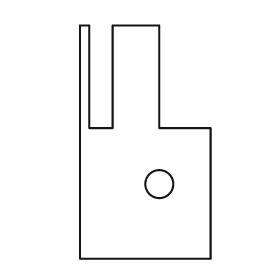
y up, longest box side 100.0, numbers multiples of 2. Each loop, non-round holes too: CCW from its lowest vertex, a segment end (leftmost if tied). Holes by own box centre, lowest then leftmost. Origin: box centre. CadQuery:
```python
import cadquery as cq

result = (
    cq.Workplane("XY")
    .moveTo(-28.0, -50.0)
    .lineTo(28.0, -50.0)
    .lineTo(28.0, 6.0)
    .lineTo(6.0, 6.0)
    .lineTo(6.0, 50.0)
    .lineTo(-14.0, 50.0)
    .lineTo(-14.0, 6.0)
    .lineTo(-24.0, 6.0)
    .lineTo(-24.0, 50.0)
    .lineTo(-28.0, 50.0)
    .close()
    .moveTo(6.0, -18.0)
    .circle(6.0)
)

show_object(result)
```